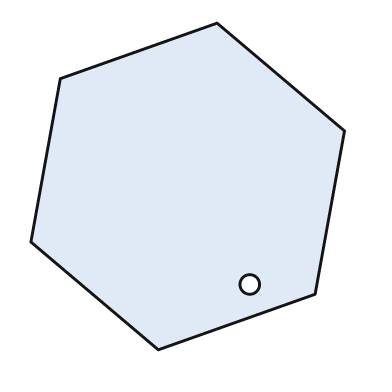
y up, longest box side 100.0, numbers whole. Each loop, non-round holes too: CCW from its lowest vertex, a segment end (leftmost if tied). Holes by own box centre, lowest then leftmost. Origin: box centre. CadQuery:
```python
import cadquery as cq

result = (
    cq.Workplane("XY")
    .moveTo(-9.0, -50.0)
    .lineTo(39.0, -33.0)
    .lineTo(48.0, 17.0)
    .lineTo(9.0, 50.0)
    .lineTo(-39.0, 33.0)
    .lineTo(-48.0, -17.0)
    .close()
    .moveTo(19.0, -30.0)
    .circle(3.0)
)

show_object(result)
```